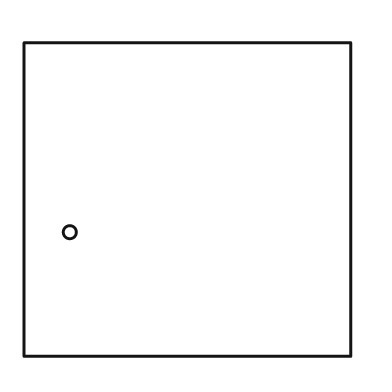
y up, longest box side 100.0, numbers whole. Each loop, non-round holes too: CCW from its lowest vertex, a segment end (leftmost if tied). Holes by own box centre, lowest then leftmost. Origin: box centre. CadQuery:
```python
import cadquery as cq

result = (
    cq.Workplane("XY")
    .moveTo(-50.0, -48.0)
    .lineTo(50.0, -48.0)
    .lineTo(50.0, 48.0)
    .lineTo(-50.0, 48.0)
    .close()
    .moveTo(-36.0, -10.0)
    .circle(2.0)
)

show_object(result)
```